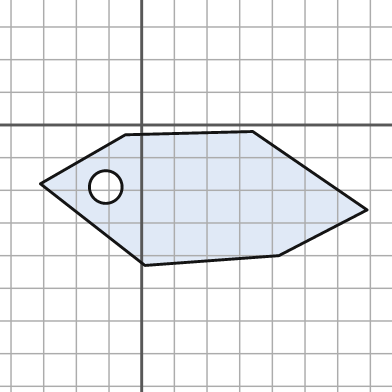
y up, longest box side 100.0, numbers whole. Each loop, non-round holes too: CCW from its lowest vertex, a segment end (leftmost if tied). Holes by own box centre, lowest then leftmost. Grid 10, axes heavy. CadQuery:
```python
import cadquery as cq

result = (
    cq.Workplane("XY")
    .moveTo(1.0, -43.0)
    .lineTo(42.0, -40.0)
    .lineTo(69.0, -26.0)
    .lineTo(34.0, -2.0)
    .lineTo(-5.0, -3.0)
    .lineTo(-31.0, -18.0)
    .close()
    .moveTo(-11.0, -19.0)
    .circle(5.0)
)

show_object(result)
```